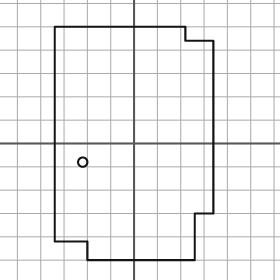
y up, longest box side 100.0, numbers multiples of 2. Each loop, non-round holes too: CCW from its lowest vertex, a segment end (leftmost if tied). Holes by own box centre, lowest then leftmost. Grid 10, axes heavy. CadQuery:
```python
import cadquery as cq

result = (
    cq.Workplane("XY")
    .moveTo(-20.0, -50.0)
    .lineTo(26.0, -50.0)
    .lineTo(26.0, -30.0)
    .lineTo(34.0, -30.0)
    .lineTo(34.0, 44.0)
    .lineTo(22.0, 44.0)
    .lineTo(22.0, 50.0)
    .lineTo(-34.0, 50.0)
    .lineTo(-34.0, -42.0)
    .lineTo(-20.0, -42.0)
    .close()
    .moveTo(-22.0, -8.0)
    .circle(2.0)
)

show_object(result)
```